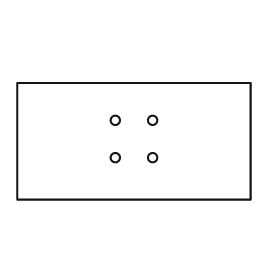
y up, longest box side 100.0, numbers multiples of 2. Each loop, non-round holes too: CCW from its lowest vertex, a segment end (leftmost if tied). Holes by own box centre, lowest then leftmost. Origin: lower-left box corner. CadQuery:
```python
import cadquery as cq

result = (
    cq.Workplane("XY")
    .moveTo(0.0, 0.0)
    .lineTo(100.0, 0.0)
    .lineTo(100.0, 50.0)
    .lineTo(0.0, 50.0)
    .close()
    .moveTo(42.0, 18.0)
    .circle(2.0)
    .moveTo(58.0, 18.0)
    .circle(2.0)
    .moveTo(42.0, 34.0)
    .circle(2.0)
    .moveTo(58.0, 34.0)
    .circle(2.0)
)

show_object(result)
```